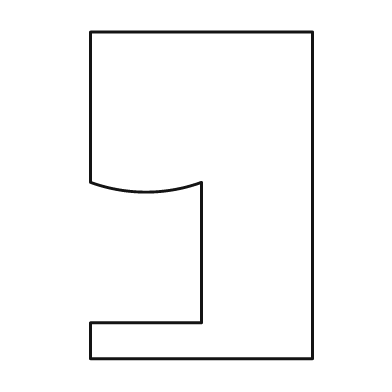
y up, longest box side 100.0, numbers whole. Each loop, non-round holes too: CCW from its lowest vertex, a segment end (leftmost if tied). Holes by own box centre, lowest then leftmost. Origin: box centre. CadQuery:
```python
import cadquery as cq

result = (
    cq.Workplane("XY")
    .moveTo(-34.0, -50.0)
    .lineTo(34.0, -50.0)
    .lineTo(34.0, 50.0)
    .lineTo(-34.0, 50.0)
    .lineTo(-34.0, 4.0)
    .threePointArc((-17.0, 1.0), (0.0, 4.0))
    .lineTo(0.0, -39.0)
    .lineTo(-34.0, -39.0)
    .close()
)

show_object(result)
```